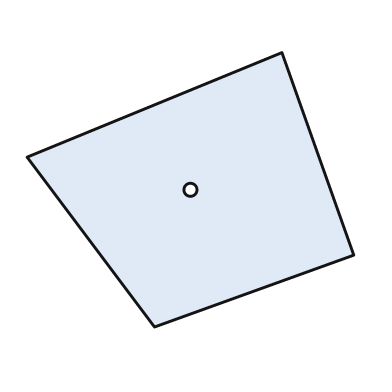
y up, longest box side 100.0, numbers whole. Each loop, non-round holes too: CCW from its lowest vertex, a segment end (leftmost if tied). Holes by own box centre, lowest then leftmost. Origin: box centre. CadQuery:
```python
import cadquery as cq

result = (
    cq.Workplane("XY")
    .moveTo(-11.0, -42.0)
    .lineTo(50.0, -20.0)
    .lineTo(28.0, 42.0)
    .lineTo(-50.0, 10.0)
    .close()
    .moveTo(0.0, 0.0)
    .circle(2.0)
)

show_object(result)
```